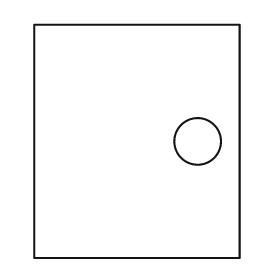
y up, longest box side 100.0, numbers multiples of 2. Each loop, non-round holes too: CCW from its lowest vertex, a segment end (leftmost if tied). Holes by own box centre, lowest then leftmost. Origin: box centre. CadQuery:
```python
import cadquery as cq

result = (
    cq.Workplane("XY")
    .moveTo(-44.0, -50.0)
    .lineTo(44.0, -50.0)
    .lineTo(44.0, 50.0)
    .lineTo(-44.0, 50.0)
    .close()
    .moveTo(26.0, 0.0)
    .circle(10.0)
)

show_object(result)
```